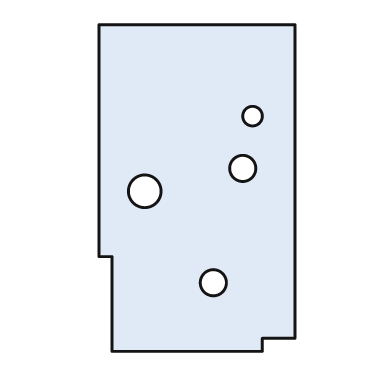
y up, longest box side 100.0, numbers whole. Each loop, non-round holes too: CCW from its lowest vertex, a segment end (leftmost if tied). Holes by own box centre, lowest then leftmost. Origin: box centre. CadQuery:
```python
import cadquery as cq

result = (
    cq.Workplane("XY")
    .moveTo(-26.0, -50.0)
    .lineTo(20.0, -50.0)
    .lineTo(20.0, -46.0)
    .lineTo(30.0, -46.0)
    .lineTo(30.0, 50.0)
    .lineTo(-30.0, 50.0)
    .lineTo(-30.0, -21.0)
    .lineTo(-26.0, -21.0)
    .close()
    .moveTo(5.0, -29.0)
    .circle(4.0)
    .moveTo(-16.0, -1.0)
    .circle(5.0)
    .moveTo(14.0, 6.0)
    .circle(4.0)
    .moveTo(17.0, 22.0)
    .circle(3.0)
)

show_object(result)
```